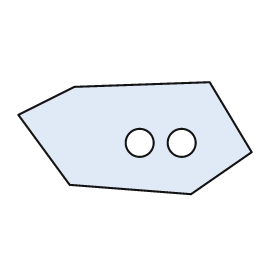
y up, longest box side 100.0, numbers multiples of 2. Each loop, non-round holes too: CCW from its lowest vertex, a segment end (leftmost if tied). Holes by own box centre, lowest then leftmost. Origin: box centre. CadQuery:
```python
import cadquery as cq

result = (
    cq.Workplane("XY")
    .moveTo(24.0, -24.0)
    .lineTo(50.0, -6.0)
    .lineTo(32.0, 24.0)
    .lineTo(-26.0, 22.0)
    .lineTo(-50.0, 10.0)
    .lineTo(-28.0, -20.0)
    .close()
    .moveTo(2.0, -2.0)
    .circle(6.0)
    .moveTo(20.0, -2.0)
    .circle(6.0)
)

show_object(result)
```